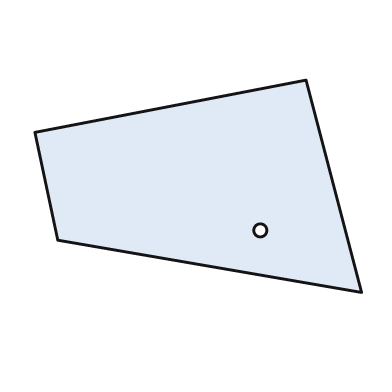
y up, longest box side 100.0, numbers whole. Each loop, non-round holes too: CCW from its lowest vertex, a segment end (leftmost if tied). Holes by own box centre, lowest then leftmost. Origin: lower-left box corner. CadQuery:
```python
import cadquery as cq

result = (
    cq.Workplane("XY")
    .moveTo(100.0, 0.0)
    .lineTo(83.0, 65.0)
    .lineTo(0.0, 49.0)
    .lineTo(7.0, 16.0)
    .close()
    .moveTo(69.0, 19.0)
    .circle(2.0)
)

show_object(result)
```